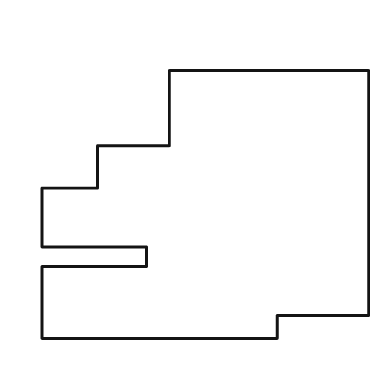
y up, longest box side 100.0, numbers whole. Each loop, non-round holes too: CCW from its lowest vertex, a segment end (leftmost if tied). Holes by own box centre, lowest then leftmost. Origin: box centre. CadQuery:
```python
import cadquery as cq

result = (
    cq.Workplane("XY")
    .moveTo(-50.0, -41.0)
    .lineTo(22.0, -41.0)
    .lineTo(22.0, -34.0)
    .lineTo(50.0, -34.0)
    .lineTo(50.0, 41.0)
    .lineTo(-11.0, 41.0)
    .lineTo(-11.0, 18.0)
    .lineTo(-33.0, 18.0)
    .lineTo(-33.0, 5.0)
    .lineTo(-50.0, 5.0)
    .lineTo(-50.0, -13.0)
    .lineTo(-18.0, -13.0)
    .lineTo(-18.0, -19.0)
    .lineTo(-50.0, -19.0)
    .close()
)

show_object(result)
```